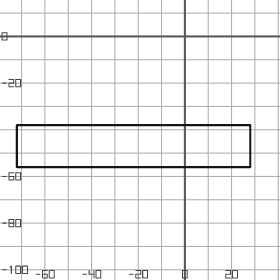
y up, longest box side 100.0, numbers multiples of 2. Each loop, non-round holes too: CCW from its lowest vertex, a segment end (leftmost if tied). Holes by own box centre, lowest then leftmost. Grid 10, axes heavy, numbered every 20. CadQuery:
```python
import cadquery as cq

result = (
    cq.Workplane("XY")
    .moveTo(-72.0, -56.0)
    .lineTo(28.0, -56.0)
    .lineTo(28.0, -38.0)
    .lineTo(-72.0, -38.0)
    .close()
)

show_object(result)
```